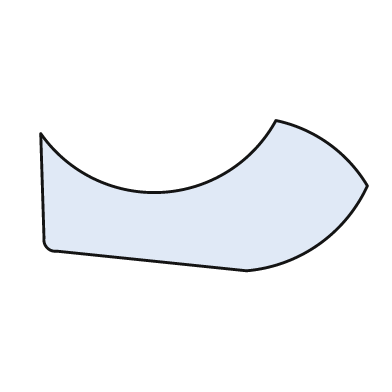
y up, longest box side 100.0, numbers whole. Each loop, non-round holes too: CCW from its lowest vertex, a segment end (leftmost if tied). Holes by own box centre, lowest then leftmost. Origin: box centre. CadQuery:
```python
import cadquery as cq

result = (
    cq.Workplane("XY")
    .moveTo(13.0, -23.0)
    .threePointArc((35.0, -15.0), (50.0, 3.0))
    .threePointArc((38.0, 16.0), (22.0, 23.0))
    .threePointArc((-13.0, 1.0), (-50.0, 19.0))
    .lineTo(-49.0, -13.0)
    .threePointArc((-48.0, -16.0), (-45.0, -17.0))
    .close()
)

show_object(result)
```